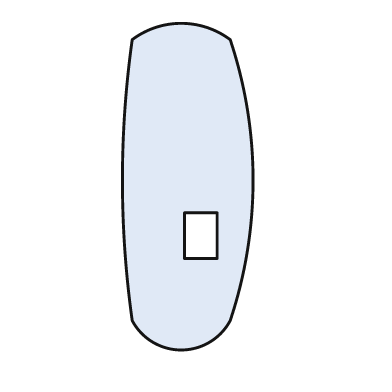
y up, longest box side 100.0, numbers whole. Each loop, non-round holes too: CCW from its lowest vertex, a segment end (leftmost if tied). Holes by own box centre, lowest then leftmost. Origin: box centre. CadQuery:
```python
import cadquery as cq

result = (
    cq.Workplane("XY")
    .moveTo(-17.0, -41.0)
    .threePointArc((-2.0, -50.0), (13.0, -41.0))
    .threePointArc((20.0, 2.0), (13.0, 45.0))
    .threePointArc((-2.0, 50.0), (-17.0, 45.0))
    .threePointArc((-20.0, 2.0), (-17.0, -41.0))
    .close()
    .moveTo(-1.0, -22.0)
    .lineTo(9.0, -22.0)
    .lineTo(9.0, -8.0)
    .lineTo(-1.0, -8.0)
    .close()
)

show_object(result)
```